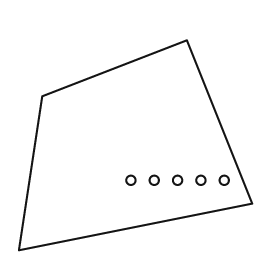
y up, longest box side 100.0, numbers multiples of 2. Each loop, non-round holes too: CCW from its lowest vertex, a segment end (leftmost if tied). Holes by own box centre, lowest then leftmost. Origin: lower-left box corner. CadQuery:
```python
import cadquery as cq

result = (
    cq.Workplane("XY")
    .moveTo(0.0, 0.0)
    .lineTo(100.0, 20.0)
    .lineTo(72.0, 90.0)
    .lineTo(10.0, 66.0)
    .close()
    .moveTo(48.0, 30.0)
    .circle(2.0)
    .moveTo(58.0, 30.0)
    .circle(2.0)
    .moveTo(68.0, 30.0)
    .circle(2.0)
    .moveTo(78.0, 30.0)
    .circle(2.0)
    .moveTo(88.0, 30.0)
    .circle(2.0)
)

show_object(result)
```